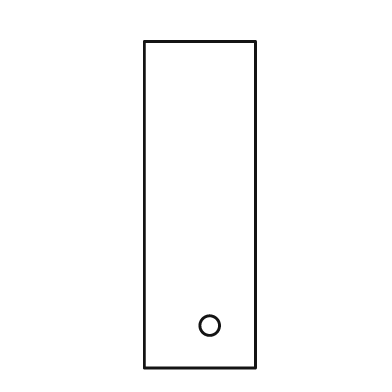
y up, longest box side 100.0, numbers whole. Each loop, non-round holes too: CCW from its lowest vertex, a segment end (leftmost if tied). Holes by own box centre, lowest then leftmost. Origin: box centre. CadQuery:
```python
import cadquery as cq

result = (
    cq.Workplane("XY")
    .moveTo(-17.0, -50.0)
    .lineTo(17.0, -50.0)
    .lineTo(17.0, 50.0)
    .lineTo(-17.0, 50.0)
    .close()
    .moveTo(3.0, -37.0)
    .circle(3.0)
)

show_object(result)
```